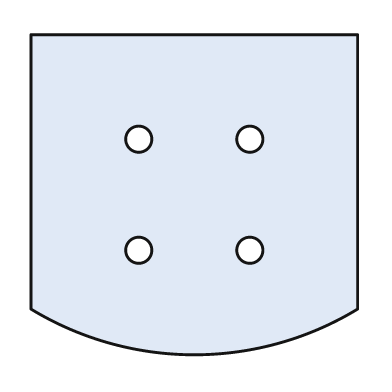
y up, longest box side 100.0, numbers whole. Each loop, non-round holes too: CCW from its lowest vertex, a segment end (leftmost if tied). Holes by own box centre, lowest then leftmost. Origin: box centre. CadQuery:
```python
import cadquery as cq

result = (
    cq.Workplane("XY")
    .moveTo(-50.0, -35.0)
    .threePointArc((0.0, -49.0), (50.0, -35.0))
    .lineTo(50.0, 49.0)
    .lineTo(-50.0, 49.0)
    .close()
    .moveTo(-17.0, -17.0)
    .circle(4.0)
    .moveTo(17.0, -17.0)
    .circle(4.0)
    .moveTo(-17.0, 17.0)
    .circle(4.0)
    .moveTo(17.0, 17.0)
    .circle(4.0)
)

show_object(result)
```